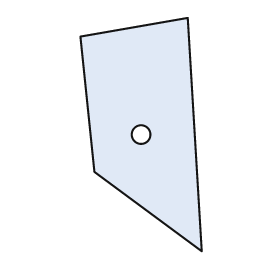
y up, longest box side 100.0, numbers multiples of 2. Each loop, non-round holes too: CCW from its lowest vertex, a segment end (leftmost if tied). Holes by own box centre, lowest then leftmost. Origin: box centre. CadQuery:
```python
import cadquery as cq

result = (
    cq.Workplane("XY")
    .moveTo(26.0, -50.0)
    .lineTo(20.0, 50.0)
    .lineTo(-26.0, 42.0)
    .lineTo(-20.0, -16.0)
    .close()
    .moveTo(0.0, 0.0)
    .circle(4.0)
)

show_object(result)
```